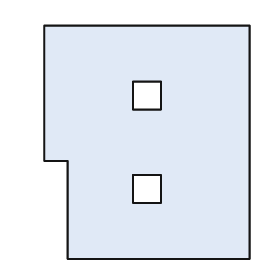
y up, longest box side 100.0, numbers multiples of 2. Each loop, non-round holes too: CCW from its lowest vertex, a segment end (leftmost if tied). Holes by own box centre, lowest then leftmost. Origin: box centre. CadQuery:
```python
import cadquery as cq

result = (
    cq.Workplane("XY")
    .moveTo(-34.0, -50.0)
    .lineTo(44.0, -50.0)
    .lineTo(44.0, 50.0)
    .lineTo(-44.0, 50.0)
    .lineTo(-44.0, -8.0)
    .lineTo(-34.0, -8.0)
    .close()
    .moveTo(-6.0, -26.0)
    .lineTo(6.0, -26.0)
    .lineTo(6.0, -14.0)
    .lineTo(-6.0, -14.0)
    .close()
    .moveTo(-6.0, 14.0)
    .lineTo(6.0, 14.0)
    .lineTo(6.0, 26.0)
    .lineTo(-6.0, 26.0)
    .close()
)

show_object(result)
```